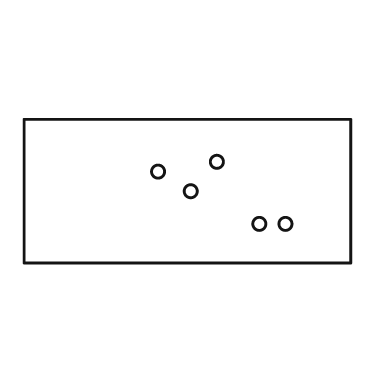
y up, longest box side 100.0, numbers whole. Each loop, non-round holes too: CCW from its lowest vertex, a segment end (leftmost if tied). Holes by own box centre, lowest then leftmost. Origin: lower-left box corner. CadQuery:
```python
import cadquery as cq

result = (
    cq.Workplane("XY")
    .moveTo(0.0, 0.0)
    .lineTo(100.0, 0.0)
    .lineTo(100.0, 44.0)
    .lineTo(0.0, 44.0)
    .close()
    .moveTo(72.0, 12.0)
    .circle(2.0)
    .moveTo(80.0, 12.0)
    .circle(2.0)
    .moveTo(51.0, 22.0)
    .circle(2.0)
    .moveTo(41.0, 28.0)
    .circle(2.0)
    .moveTo(59.0, 31.0)
    .circle(2.0)
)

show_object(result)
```